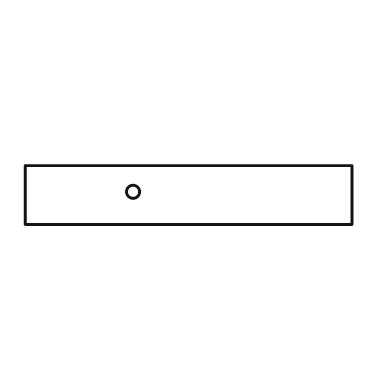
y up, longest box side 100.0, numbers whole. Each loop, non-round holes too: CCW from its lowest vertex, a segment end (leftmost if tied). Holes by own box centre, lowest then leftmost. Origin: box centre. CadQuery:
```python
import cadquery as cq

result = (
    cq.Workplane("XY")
    .moveTo(-50.0, -9.0)
    .lineTo(50.0, -9.0)
    .lineTo(50.0, 9.0)
    .lineTo(-50.0, 9.0)
    .close()
    .moveTo(-17.0, 1.0)
    .circle(2.0)
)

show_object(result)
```